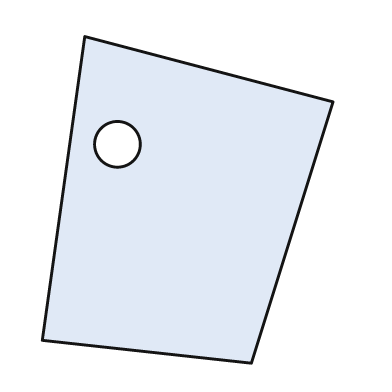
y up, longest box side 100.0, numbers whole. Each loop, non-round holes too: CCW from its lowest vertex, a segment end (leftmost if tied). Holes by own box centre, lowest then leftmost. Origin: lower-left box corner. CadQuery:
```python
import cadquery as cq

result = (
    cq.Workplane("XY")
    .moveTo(64.0, 0.0)
    .lineTo(89.0, 80.0)
    .lineTo(13.0, 100.0)
    .lineTo(0.0, 7.0)
    .close()
    .moveTo(23.0, 67.0)
    .circle(7.0)
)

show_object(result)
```